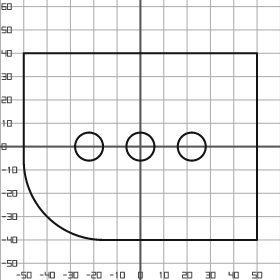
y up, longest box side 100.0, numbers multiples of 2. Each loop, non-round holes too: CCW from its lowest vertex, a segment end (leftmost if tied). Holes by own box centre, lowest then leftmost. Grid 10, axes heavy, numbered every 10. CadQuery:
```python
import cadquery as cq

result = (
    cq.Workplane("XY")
    .moveTo(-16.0, -40.0)
    .lineTo(50.0, -40.0)
    .lineTo(50.0, 40.0)
    .lineTo(-50.0, 40.0)
    .lineTo(-50.0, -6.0)
    .threePointArc((-40.0, -30.0), (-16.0, -40.0))
    .close()
    .moveTo(-22.0, 0.0)
    .circle(6.0)
    .moveTo(0.0, 0.0)
    .circle(6.0)
    .moveTo(22.0, 0.0)
    .circle(6.0)
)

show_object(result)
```